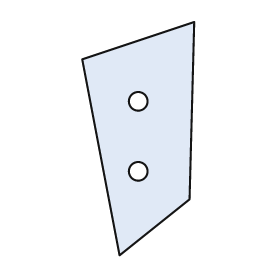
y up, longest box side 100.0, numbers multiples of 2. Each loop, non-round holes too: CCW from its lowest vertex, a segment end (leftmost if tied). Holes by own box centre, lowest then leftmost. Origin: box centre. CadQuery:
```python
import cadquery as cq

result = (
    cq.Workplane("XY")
    .moveTo(-8.0, -50.0)
    .lineTo(22.0, -26.0)
    .lineTo(24.0, 50.0)
    .lineTo(-24.0, 34.0)
    .close()
    .moveTo(0.0, -14.0)
    .circle(4.0)
    .moveTo(0.0, 16.0)
    .circle(4.0)
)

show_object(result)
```